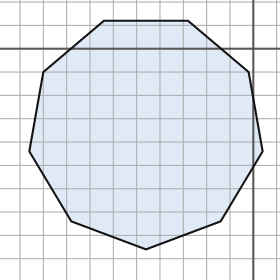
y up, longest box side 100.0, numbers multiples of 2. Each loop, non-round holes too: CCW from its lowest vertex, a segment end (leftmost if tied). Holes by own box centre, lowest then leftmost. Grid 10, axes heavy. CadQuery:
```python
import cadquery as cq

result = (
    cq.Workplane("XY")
    .moveTo(-46.0, -86.0)
    .lineTo(-14.0, -74.0)
    .lineTo(4.0, -44.0)
    .lineTo(-2.0, -10.0)
    .lineTo(-28.0, 12.0)
    .lineTo(-64.0, 12.0)
    .lineTo(-90.0, -10.0)
    .lineTo(-96.0, -44.0)
    .lineTo(-78.0, -74.0)
    .close()
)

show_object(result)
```